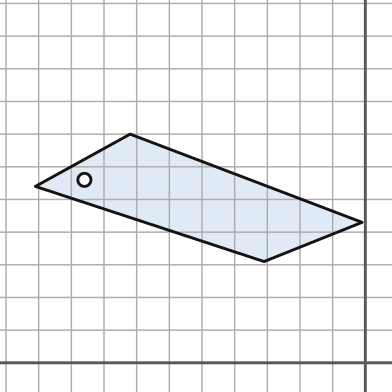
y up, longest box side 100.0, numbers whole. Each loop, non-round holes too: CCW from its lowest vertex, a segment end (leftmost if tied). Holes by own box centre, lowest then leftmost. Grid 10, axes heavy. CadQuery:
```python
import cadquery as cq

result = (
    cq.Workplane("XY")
    .moveTo(-31.0, 31.0)
    .lineTo(-1.0, 43.0)
    .lineTo(-72.0, 70.0)
    .lineTo(-101.0, 54.0)
    .close()
    .moveTo(-86.0, 56.0)
    .circle(2.0)
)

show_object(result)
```